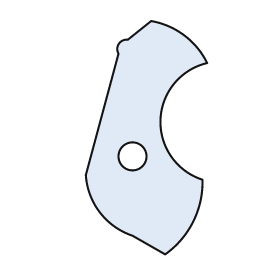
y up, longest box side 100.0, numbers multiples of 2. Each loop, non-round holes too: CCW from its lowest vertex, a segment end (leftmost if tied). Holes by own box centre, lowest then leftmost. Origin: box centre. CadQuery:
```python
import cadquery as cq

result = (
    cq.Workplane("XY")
    .moveTo(8.0, -50.0)
    .threePointArc((20.0, -36.0), (24.0, -18.0))
    .threePointArc((6.0, 8.0), (26.0, 32.0))
    .threePointArc((16.0, 44.0), (2.0, 50.0))
    .lineTo(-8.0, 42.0)
    .threePointArc((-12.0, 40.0), (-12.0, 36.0))
    .lineTo(-26.0, -16.0)
    .threePointArc((-20.0, -32.0), (-6.0, -42.0))
    .close()
    .moveTo(-6.0, -8.0)
    .circle(6.0)
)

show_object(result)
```